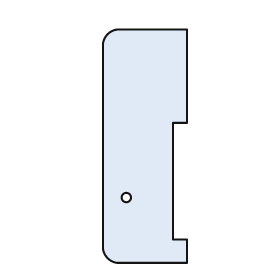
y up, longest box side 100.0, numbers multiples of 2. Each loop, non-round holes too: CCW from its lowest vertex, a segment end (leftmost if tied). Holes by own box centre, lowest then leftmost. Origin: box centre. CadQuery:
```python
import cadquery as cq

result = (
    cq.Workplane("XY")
    .moveTo(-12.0, -50.0)
    .lineTo(18.0, -50.0)
    .lineTo(18.0, -40.0)
    .lineTo(12.0, -40.0)
    .lineTo(12.0, 10.0)
    .lineTo(18.0, 10.0)
    .lineTo(18.0, 50.0)
    .lineTo(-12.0, 50.0)
    .threePointArc((-16.0, 48.0), (-18.0, 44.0))
    .lineTo(-18.0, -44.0)
    .threePointArc((-16.0, -48.0), (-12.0, -50.0))
    .close()
    .moveTo(-8.0, -22.0)
    .circle(2.0)
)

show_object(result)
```